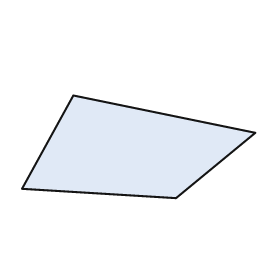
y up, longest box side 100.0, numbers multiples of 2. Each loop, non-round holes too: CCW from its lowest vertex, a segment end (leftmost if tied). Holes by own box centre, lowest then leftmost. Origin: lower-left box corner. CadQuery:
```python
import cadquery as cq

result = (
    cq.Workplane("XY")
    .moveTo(66.0, 0.0)
    .lineTo(100.0, 28.0)
    .lineTo(22.0, 44.0)
    .lineTo(0.0, 4.0)
    .close()
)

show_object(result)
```